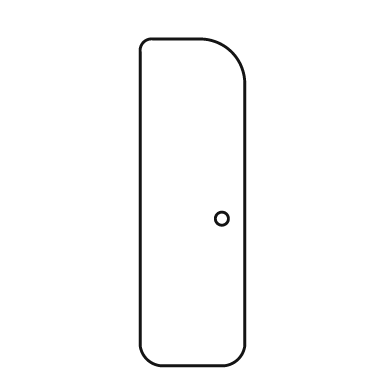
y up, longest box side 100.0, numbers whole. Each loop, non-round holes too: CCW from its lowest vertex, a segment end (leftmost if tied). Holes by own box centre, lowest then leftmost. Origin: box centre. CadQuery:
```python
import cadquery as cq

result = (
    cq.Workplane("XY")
    .moveTo(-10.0, -50.0)
    .lineTo(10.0, -50.0)
    .threePointArc((14.0, -48.0), (16.0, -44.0))
    .lineTo(16.0, 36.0)
    .threePointArc((12.0, 46.0), (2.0, 50.0))
    .lineTo(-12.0, 50.0)
    .threePointArc((-15.0, 49.0), (-16.0, 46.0))
    .lineTo(-16.0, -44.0)
    .threePointArc((-14.0, -48.0), (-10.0, -50.0))
    .close()
    .moveTo(9.0, -5.0)
    .circle(2.0)
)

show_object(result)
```